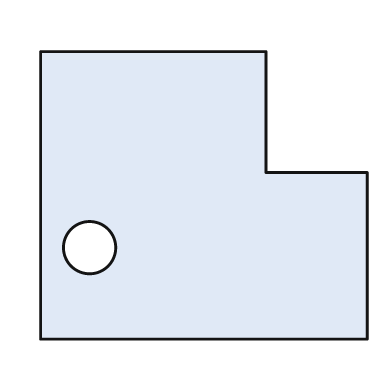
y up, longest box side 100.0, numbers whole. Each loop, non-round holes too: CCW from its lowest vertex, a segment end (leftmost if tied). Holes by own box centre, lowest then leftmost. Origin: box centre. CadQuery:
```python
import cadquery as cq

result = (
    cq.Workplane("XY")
    .moveTo(-50.0, -44.0)
    .lineTo(50.0, -44.0)
    .lineTo(50.0, 7.0)
    .lineTo(19.0, 7.0)
    .lineTo(19.0, 44.0)
    .lineTo(-50.0, 44.0)
    .close()
    .moveTo(-35.0, -16.0)
    .circle(8.0)
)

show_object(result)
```